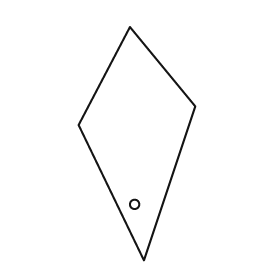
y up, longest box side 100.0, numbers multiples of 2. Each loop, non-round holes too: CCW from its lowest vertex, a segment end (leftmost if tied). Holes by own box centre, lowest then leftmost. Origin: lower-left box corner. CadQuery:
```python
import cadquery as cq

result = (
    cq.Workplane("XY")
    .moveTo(28.0, 0.0)
    .lineTo(50.0, 66.0)
    .lineTo(22.0, 100.0)
    .lineTo(0.0, 58.0)
    .close()
    .moveTo(24.0, 24.0)
    .circle(2.0)
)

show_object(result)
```